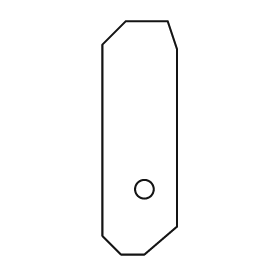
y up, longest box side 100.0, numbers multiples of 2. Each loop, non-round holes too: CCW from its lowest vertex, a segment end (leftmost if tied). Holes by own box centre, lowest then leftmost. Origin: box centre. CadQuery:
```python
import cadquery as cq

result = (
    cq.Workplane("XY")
    .moveTo(-8.0, -50.0)
    .lineTo(2.0, -50.0)
    .lineTo(16.0, -38.0)
    .lineTo(16.0, 38.0)
    .lineTo(12.0, 50.0)
    .lineTo(-6.0, 50.0)
    .lineTo(-16.0, 40.0)
    .lineTo(-16.0, -42.0)
    .close()
    .moveTo(2.0, -22.0)
    .circle(4.0)
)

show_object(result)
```